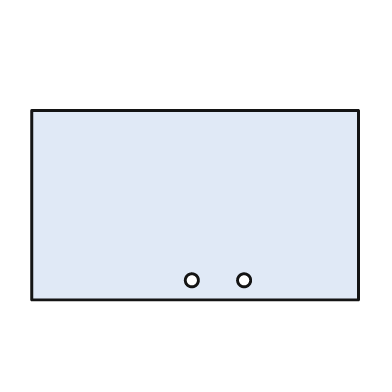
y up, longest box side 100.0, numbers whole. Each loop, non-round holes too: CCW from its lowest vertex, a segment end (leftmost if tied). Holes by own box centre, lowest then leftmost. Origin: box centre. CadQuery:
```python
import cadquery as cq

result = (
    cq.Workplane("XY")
    .moveTo(-50.0, -29.0)
    .lineTo(50.0, -29.0)
    .lineTo(50.0, 29.0)
    .lineTo(-50.0, 29.0)
    .close()
    .moveTo(-1.0, -23.0)
    .circle(2.0)
    .moveTo(15.0, -23.0)
    .circle(2.0)
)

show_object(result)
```